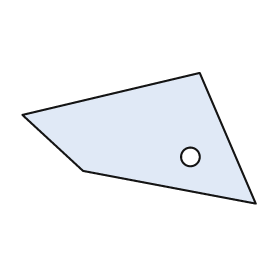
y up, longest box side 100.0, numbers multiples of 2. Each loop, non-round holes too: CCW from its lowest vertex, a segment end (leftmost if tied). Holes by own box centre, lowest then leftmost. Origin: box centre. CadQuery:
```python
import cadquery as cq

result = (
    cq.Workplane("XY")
    .moveTo(50.0, -28.0)
    .lineTo(26.0, 28.0)
    .lineTo(-50.0, 10.0)
    .lineTo(-24.0, -14.0)
    .close()
    .moveTo(22.0, -8.0)
    .circle(4.0)
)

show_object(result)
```